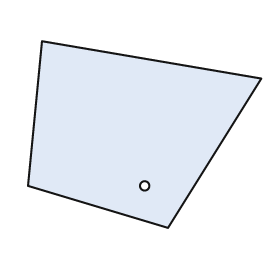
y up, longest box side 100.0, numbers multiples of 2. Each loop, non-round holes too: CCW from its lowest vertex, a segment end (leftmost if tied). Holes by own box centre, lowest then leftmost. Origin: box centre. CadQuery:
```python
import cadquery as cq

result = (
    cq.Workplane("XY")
    .moveTo(10.0, -40.0)
    .lineTo(50.0, 24.0)
    .lineTo(-44.0, 40.0)
    .lineTo(-50.0, -22.0)
    .close()
    .moveTo(0.0, -22.0)
    .circle(2.0)
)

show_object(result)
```